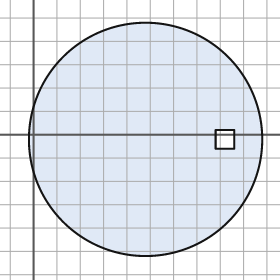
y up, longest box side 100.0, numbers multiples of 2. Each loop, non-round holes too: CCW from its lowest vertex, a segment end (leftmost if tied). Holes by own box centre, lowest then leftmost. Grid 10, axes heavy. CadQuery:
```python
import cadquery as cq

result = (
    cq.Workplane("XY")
    .moveTo(48.0, -2.0)
    .circle(50.0)
    .moveTo(78.0, -6.0)
    .lineTo(86.0, -6.0)
    .lineTo(86.0, 2.0)
    .lineTo(78.0, 2.0)
    .close()
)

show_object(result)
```